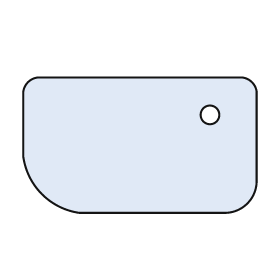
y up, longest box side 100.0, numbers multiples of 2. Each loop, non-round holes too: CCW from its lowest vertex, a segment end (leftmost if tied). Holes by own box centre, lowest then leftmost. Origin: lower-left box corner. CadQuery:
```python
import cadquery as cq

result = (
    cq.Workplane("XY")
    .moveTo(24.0, 0.0)
    .lineTo(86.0, 0.0)
    .threePointArc((96.0, 4.0), (100.0, 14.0))
    .lineTo(100.0, 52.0)
    .threePointArc((98.0, 56.0), (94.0, 58.0))
    .lineTo(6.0, 58.0)
    .threePointArc((2.0, 56.0), (0.0, 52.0))
    .lineTo(0.0, 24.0)
    .threePointArc((8.0, 8.0), (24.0, 0.0))
    .close()
    .moveTo(80.0, 42.0)
    .circle(4.0)
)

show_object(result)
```